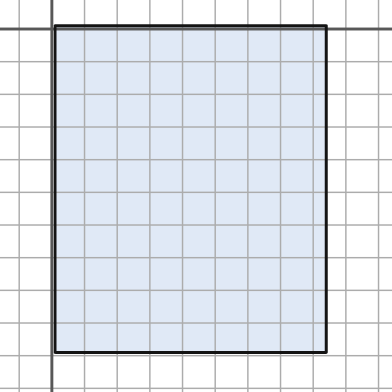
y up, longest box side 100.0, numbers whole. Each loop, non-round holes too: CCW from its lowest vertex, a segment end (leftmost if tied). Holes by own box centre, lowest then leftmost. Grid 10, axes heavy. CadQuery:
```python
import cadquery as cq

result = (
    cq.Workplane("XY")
    .moveTo(1.0, -99.0)
    .lineTo(84.0, -99.0)
    .lineTo(84.0, 1.0)
    .lineTo(1.0, 1.0)
    .close()
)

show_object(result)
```